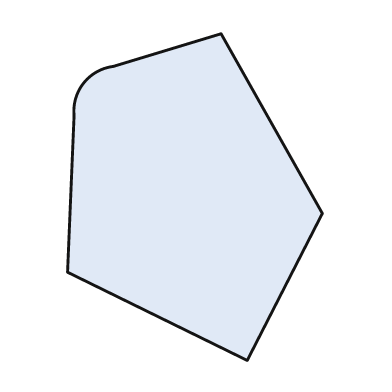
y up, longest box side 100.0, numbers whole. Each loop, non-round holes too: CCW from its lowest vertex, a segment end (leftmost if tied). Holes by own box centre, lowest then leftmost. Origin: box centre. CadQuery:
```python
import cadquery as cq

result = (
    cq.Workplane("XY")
    .moveTo(16.0, -50.0)
    .lineTo(39.0, -5.0)
    .lineTo(8.0, 50.0)
    .lineTo(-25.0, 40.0)
    .threePointArc((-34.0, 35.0), (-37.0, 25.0))
    .lineTo(-39.0, -23.0)
    .close()
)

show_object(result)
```